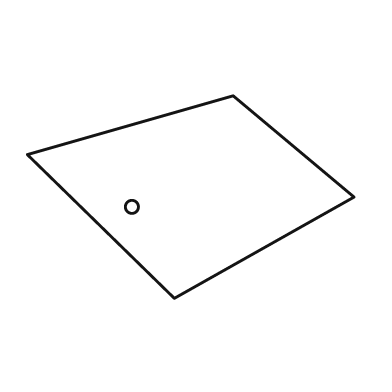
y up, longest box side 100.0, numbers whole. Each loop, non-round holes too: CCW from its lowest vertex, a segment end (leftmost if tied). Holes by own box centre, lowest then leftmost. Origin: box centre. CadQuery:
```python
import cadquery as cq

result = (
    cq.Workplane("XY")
    .moveTo(-5.0, -31.0)
    .lineTo(50.0, 0.0)
    .lineTo(13.0, 31.0)
    .lineTo(-50.0, 13.0)
    .close()
    .moveTo(-18.0, -3.0)
    .circle(2.0)
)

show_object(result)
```